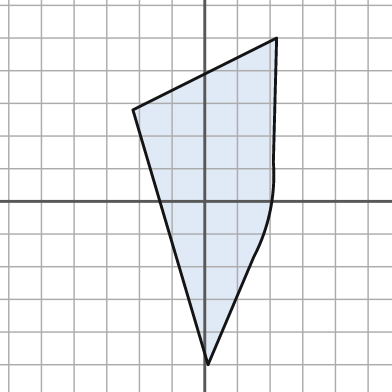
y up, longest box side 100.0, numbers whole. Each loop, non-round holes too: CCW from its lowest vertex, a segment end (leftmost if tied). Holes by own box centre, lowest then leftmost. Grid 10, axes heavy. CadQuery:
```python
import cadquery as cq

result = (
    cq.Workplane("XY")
    .moveTo(1.0, -50.0)
    .lineTo(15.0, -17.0)
    .threePointArc((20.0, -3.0), (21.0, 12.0))
    .lineTo(22.0, 50.0)
    .lineTo(-22.0, 28.0)
    .close()
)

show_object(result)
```